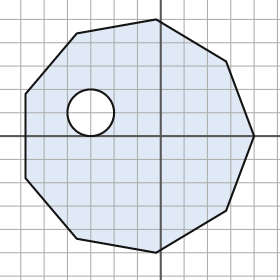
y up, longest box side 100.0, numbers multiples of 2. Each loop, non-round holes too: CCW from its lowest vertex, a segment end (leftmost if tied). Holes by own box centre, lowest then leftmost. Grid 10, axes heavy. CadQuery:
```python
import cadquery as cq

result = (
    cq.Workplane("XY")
    .moveTo(-2.0, -50.0)
    .lineTo(28.0, -32.0)
    .lineTo(40.0, 0.0)
    .lineTo(28.0, 32.0)
    .lineTo(-2.0, 50.0)
    .lineTo(-36.0, 44.0)
    .lineTo(-58.0, 18.0)
    .lineTo(-58.0, -18.0)
    .lineTo(-36.0, -44.0)
    .close()
    .moveTo(-30.0, 10.0)
    .circle(10.0)
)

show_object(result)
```